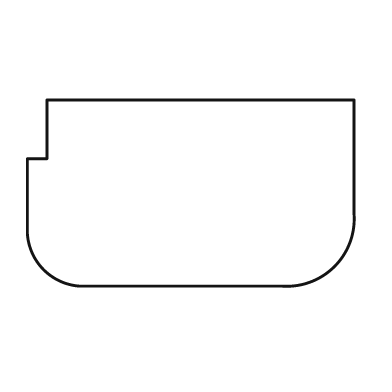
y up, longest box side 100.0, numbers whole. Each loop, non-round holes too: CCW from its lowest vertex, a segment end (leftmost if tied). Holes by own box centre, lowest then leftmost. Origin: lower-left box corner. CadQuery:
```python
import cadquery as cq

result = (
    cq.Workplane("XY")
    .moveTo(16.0, 0.0)
    .lineTo(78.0, 0.0)
    .threePointArc((94.0, 6.0), (100.0, 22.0))
    .lineTo(100.0, 57.0)
    .lineTo(6.0, 57.0)
    .lineTo(6.0, 39.0)
    .lineTo(0.0, 39.0)
    .lineTo(0.0, 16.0)
    .threePointArc((5.0, 5.0), (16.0, 0.0))
    .close()
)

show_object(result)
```